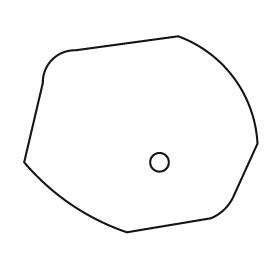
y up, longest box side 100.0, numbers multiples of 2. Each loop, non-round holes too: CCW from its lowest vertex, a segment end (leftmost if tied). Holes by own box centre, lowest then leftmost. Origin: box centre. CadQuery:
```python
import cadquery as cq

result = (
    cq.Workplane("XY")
    .moveTo(-6.0, -42.0)
    .lineTo(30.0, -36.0)
    .threePointArc((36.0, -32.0), (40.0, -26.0))
    .lineTo(50.0, -4.0)
    .threePointArc((40.0, 24.0), (16.0, 42.0))
    .lineTo(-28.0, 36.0)
    .threePointArc((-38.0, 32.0), (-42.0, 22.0))
    .lineTo(-50.0, -12.0)
    .threePointArc((-30.0, -30.0), (-6.0, -42.0))
    .close()
    .moveTo(8.0, -12.0)
    .circle(4.0)
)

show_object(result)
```